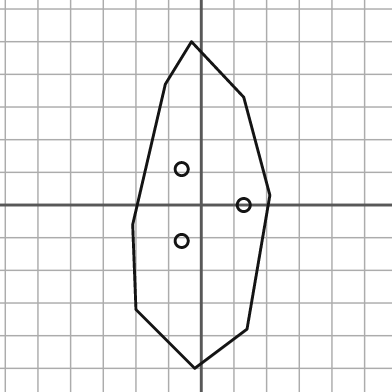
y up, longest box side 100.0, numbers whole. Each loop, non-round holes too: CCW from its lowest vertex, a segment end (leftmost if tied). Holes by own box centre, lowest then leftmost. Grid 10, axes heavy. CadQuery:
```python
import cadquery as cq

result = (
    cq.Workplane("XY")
    .moveTo(-2.0, -50.0)
    .lineTo(14.0, -38.0)
    .lineTo(21.0, 3.0)
    .lineTo(13.0, 33.0)
    .lineTo(-3.0, 50.0)
    .lineTo(-11.0, 37.0)
    .lineTo(-21.0, -6.0)
    .lineTo(-20.0, -32.0)
    .close()
    .moveTo(-6.0, -11.0)
    .circle(2.0)
    .moveTo(13.0, 0.0)
    .circle(2.0)
    .moveTo(-6.0, 11.0)
    .circle(2.0)
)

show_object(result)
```